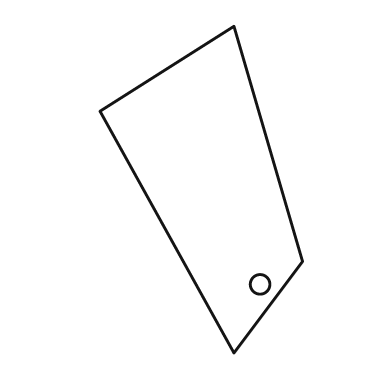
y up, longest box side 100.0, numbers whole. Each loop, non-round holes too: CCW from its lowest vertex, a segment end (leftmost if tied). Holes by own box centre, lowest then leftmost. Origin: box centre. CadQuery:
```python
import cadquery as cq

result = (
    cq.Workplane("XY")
    .moveTo(10.0, -50.0)
    .lineTo(31.0, -22.0)
    .lineTo(10.0, 50.0)
    .lineTo(-31.0, 24.0)
    .close()
    .moveTo(18.0, -29.0)
    .circle(3.0)
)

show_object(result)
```